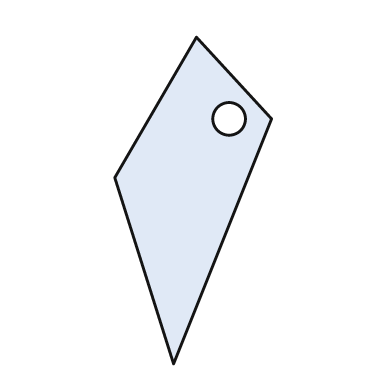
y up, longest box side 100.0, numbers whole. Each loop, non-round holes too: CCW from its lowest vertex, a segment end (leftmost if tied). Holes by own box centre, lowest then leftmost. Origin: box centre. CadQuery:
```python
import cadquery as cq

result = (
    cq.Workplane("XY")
    .moveTo(-6.0, -50.0)
    .lineTo(24.0, 25.0)
    .lineTo(1.0, 50.0)
    .lineTo(-24.0, 7.0)
    .close()
    .moveTo(11.0, 25.0)
    .circle(5.0)
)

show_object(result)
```